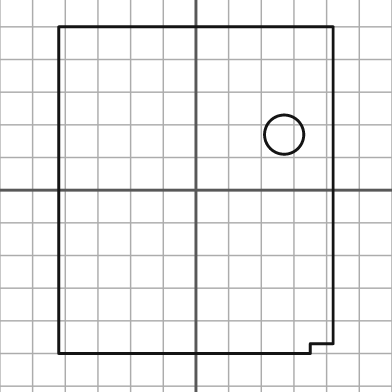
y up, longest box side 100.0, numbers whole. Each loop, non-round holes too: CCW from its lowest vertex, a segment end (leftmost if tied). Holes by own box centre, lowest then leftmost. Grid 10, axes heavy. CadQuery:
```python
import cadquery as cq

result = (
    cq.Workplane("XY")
    .moveTo(-42.0, -50.0)
    .lineTo(35.0, -50.0)
    .lineTo(35.0, -47.0)
    .lineTo(42.0, -47.0)
    .lineTo(42.0, 50.0)
    .lineTo(-42.0, 50.0)
    .close()
    .moveTo(27.0, 17.0)
    .circle(6.0)
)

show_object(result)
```